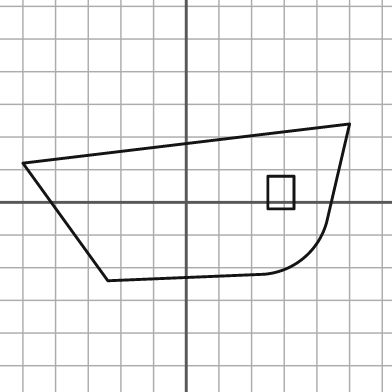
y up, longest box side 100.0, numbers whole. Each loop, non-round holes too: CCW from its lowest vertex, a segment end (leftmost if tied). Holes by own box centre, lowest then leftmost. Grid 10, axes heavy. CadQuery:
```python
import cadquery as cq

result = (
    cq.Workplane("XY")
    .moveTo(-24.0, -24.0)
    .lineTo(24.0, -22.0)
    .threePointArc((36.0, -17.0), (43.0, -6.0))
    .lineTo(50.0, 24.0)
    .lineTo(-50.0, 12.0)
    .close()
    .moveTo(25.0, -2.0)
    .lineTo(33.0, -2.0)
    .lineTo(33.0, 8.0)
    .lineTo(25.0, 8.0)
    .close()
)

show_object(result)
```